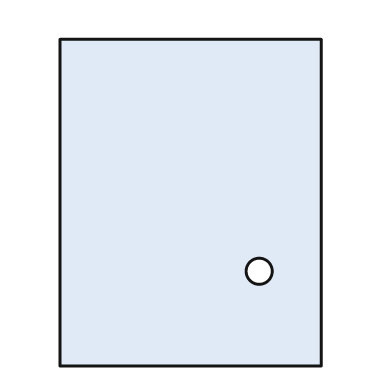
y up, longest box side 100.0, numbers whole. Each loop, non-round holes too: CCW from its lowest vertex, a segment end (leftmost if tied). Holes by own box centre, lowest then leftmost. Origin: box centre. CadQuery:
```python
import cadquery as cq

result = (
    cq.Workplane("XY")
    .moveTo(-40.0, -50.0)
    .lineTo(40.0, -50.0)
    .lineTo(40.0, 50.0)
    .lineTo(-40.0, 50.0)
    .close()
    .moveTo(21.0, -21.0)
    .circle(4.0)
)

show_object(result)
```